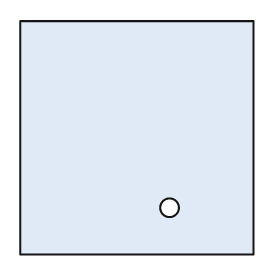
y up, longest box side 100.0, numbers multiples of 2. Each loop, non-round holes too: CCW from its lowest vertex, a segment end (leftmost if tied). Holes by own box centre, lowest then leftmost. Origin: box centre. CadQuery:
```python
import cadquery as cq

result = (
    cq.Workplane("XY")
    .moveTo(-50.0, -50.0)
    .lineTo(50.0, -50.0)
    .lineTo(50.0, 50.0)
    .lineTo(-50.0, 50.0)
    .close()
    .moveTo(14.0, -30.0)
    .circle(4.0)
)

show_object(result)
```